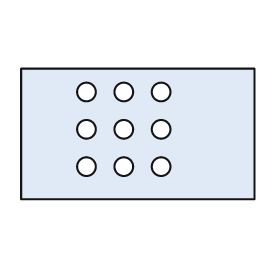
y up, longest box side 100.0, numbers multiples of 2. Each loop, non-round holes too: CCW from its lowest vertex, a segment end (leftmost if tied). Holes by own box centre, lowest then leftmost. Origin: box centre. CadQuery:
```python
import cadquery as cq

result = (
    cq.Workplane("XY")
    .moveTo(-50.0, -28.0)
    .lineTo(50.0, -28.0)
    .lineTo(50.0, 28.0)
    .lineTo(-50.0, 28.0)
    .close()
    .moveTo(-22.0, -14.0)
    .circle(4.0)
    .moveTo(-6.0, -14.0)
    .circle(4.0)
    .moveTo(10.0, -14.0)
    .circle(4.0)
    .moveTo(-22.0, 2.0)
    .circle(4.0)
    .moveTo(-6.0, 2.0)
    .circle(4.0)
    .moveTo(10.0, 2.0)
    .circle(4.0)
    .moveTo(-22.0, 18.0)
    .circle(4.0)
    .moveTo(-6.0, 18.0)
    .circle(4.0)
    .moveTo(10.0, 18.0)
    .circle(4.0)
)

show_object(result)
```